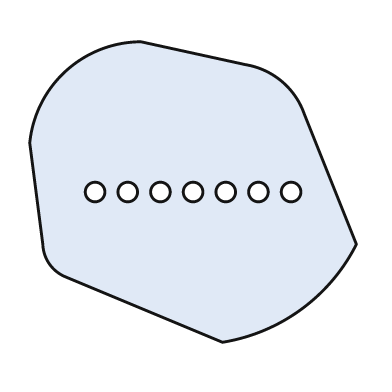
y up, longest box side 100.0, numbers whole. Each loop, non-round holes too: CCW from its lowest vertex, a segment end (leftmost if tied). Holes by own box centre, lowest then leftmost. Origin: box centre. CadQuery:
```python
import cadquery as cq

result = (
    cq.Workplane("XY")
    .moveTo(9.0, -46.0)
    .threePointArc((33.0, -36.0), (50.0, -16.0))
    .lineTo(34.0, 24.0)
    .threePointArc((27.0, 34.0), (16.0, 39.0))
    .lineTo(-16.0, 46.0)
    .threePointArc((-39.0, 37.0), (-50.0, 15.0))
    .lineTo(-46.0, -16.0)
    .threePointArc((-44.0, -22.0), (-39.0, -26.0))
    .close()
    .moveTo(-30.0, 0.0)
    .circle(3.0)
    .moveTo(-20.0, 0.0)
    .circle(3.0)
    .moveTo(-10.0, 0.0)
    .circle(3.0)
    .moveTo(0.0, 0.0)
    .circle(3.0)
    .moveTo(10.0, 0.0)
    .circle(3.0)
    .moveTo(20.0, 0.0)
    .circle(3.0)
    .moveTo(30.0, 0.0)
    .circle(3.0)
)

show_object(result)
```